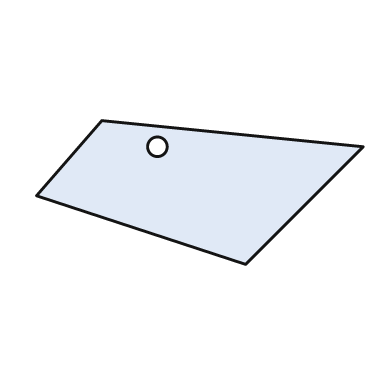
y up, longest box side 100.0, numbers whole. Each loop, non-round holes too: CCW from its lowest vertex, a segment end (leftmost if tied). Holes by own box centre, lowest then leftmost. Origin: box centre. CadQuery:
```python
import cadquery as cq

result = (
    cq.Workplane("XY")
    .moveTo(14.0, -22.0)
    .lineTo(50.0, 14.0)
    .lineTo(-30.0, 22.0)
    .lineTo(-50.0, -1.0)
    .close()
    .moveTo(-13.0, 14.0)
    .circle(3.0)
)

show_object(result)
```